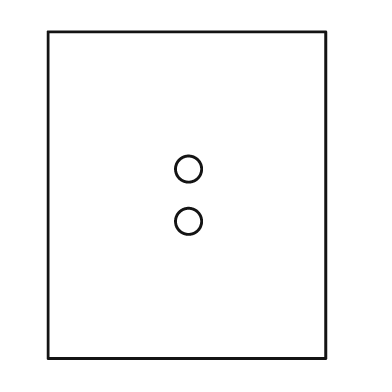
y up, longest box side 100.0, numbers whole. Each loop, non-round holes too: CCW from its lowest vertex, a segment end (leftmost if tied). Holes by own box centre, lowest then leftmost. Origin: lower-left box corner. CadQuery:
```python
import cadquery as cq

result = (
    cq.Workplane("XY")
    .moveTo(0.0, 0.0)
    .lineTo(85.0, 0.0)
    .lineTo(85.0, 100.0)
    .lineTo(0.0, 100.0)
    .close()
    .moveTo(43.0, 42.0)
    .circle(4.0)
    .moveTo(43.0, 58.0)
    .circle(4.0)
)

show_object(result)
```